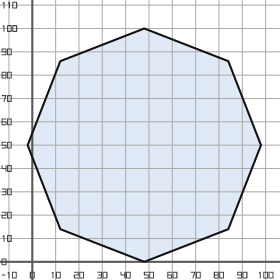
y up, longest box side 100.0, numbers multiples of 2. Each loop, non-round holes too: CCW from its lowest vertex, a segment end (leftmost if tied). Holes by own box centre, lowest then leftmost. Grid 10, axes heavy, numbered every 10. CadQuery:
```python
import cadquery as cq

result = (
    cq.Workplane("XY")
    .moveTo(48.0, 0.0)
    .lineTo(84.0, 14.0)
    .lineTo(98.0, 50.0)
    .lineTo(84.0, 86.0)
    .lineTo(48.0, 100.0)
    .lineTo(12.0, 86.0)
    .lineTo(-2.0, 50.0)
    .lineTo(12.0, 14.0)
    .close()
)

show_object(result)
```